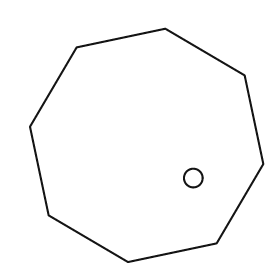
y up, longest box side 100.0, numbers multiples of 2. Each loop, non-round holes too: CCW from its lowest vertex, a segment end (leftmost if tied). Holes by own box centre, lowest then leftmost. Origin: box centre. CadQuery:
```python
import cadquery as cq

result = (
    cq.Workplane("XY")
    .moveTo(-8.0, -50.0)
    .lineTo(30.0, -42.0)
    .lineTo(50.0, -8.0)
    .lineTo(42.0, 30.0)
    .lineTo(8.0, 50.0)
    .lineTo(-30.0, 42.0)
    .lineTo(-50.0, 8.0)
    .lineTo(-42.0, -30.0)
    .close()
    .moveTo(20.0, -14.0)
    .circle(4.0)
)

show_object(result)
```